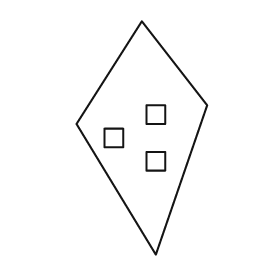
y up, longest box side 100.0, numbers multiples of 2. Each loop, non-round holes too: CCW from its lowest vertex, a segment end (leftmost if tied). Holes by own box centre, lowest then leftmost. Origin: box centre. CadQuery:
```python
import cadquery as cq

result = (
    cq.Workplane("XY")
    .moveTo(6.0, -50.0)
    .lineTo(28.0, 14.0)
    .lineTo(0.0, 50.0)
    .lineTo(-28.0, 6.0)
    .close()
    .moveTo(2.0, -14.0)
    .lineTo(10.0, -14.0)
    .lineTo(10.0, -6.0)
    .lineTo(2.0, -6.0)
    .close()
    .moveTo(-16.0, -4.0)
    .lineTo(-8.0, -4.0)
    .lineTo(-8.0, 4.0)
    .lineTo(-16.0, 4.0)
    .close()
    .moveTo(2.0, 6.0)
    .lineTo(10.0, 6.0)
    .lineTo(10.0, 14.0)
    .lineTo(2.0, 14.0)
    .close()
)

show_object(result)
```